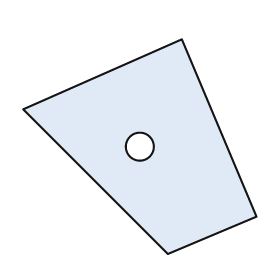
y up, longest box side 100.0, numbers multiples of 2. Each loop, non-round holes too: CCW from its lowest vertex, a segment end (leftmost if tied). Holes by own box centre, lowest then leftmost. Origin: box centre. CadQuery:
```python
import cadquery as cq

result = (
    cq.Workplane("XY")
    .moveTo(12.0, -46.0)
    .lineTo(50.0, -30.0)
    .lineTo(18.0, 46.0)
    .lineTo(-50.0, 16.0)
    .close()
    .moveTo(0.0, 0.0)
    .circle(6.0)
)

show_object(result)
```